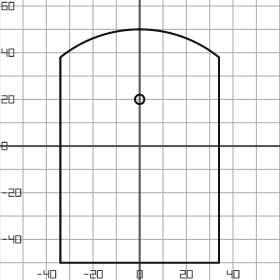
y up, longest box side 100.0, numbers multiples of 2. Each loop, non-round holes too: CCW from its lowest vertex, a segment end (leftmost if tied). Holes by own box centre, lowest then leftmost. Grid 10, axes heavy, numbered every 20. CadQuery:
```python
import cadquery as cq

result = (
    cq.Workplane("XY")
    .moveTo(-34.0, -50.0)
    .lineTo(34.0, -50.0)
    .lineTo(34.0, 38.0)
    .threePointArc((0.0, 50.0), (-34.0, 38.0))
    .close()
    .moveTo(0.0, 20.0)
    .circle(2.0)
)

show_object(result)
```